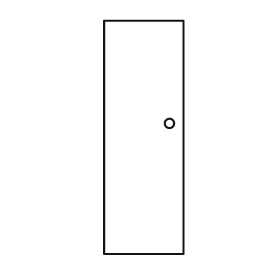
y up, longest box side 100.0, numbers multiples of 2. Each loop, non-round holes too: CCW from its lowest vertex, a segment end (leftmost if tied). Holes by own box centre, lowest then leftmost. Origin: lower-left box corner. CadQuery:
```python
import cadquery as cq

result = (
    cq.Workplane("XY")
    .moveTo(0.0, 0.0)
    .lineTo(34.0, 0.0)
    .lineTo(34.0, 100.0)
    .lineTo(0.0, 100.0)
    .close()
    .moveTo(28.0, 56.0)
    .circle(2.0)
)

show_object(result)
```